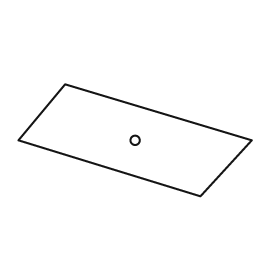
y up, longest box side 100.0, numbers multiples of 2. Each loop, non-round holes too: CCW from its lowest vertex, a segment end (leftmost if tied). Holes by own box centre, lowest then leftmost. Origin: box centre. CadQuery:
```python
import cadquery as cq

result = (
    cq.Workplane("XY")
    .moveTo(28.0, -24.0)
    .lineTo(50.0, 0.0)
    .lineTo(-30.0, 24.0)
    .lineTo(-50.0, 0.0)
    .close()
    .moveTo(0.0, 0.0)
    .circle(2.0)
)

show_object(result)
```